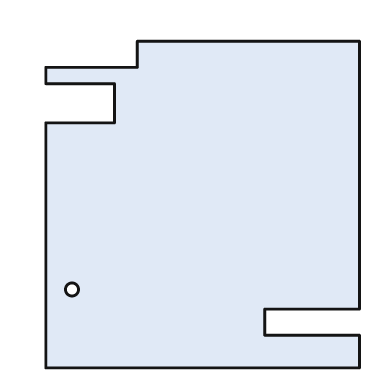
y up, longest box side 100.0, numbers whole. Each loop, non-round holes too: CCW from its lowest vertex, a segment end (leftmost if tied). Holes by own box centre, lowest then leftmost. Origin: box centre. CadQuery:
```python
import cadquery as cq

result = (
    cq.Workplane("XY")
    .moveTo(-48.0, -50.0)
    .lineTo(48.0, -50.0)
    .lineTo(48.0, -40.0)
    .lineTo(19.0, -40.0)
    .lineTo(19.0, -32.0)
    .lineTo(48.0, -32.0)
    .lineTo(48.0, 50.0)
    .lineTo(-20.0, 50.0)
    .lineTo(-20.0, 42.0)
    .lineTo(-48.0, 42.0)
    .lineTo(-48.0, 37.0)
    .lineTo(-27.0, 37.0)
    .lineTo(-27.0, 25.0)
    .lineTo(-48.0, 25.0)
    .close()
    .moveTo(-40.0, -26.0)
    .circle(2.0)
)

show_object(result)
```